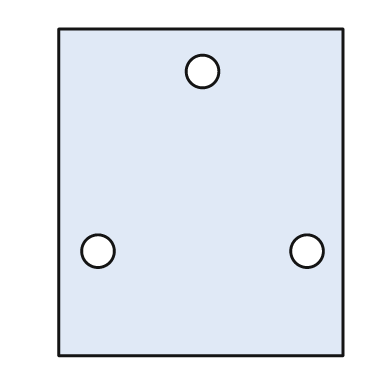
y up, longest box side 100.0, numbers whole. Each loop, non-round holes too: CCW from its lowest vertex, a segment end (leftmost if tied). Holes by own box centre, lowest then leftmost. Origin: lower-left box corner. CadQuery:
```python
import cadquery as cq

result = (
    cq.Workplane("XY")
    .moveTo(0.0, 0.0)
    .lineTo(87.0, 0.0)
    .lineTo(87.0, 100.0)
    .lineTo(0.0, 100.0)
    .close()
    .moveTo(12.0, 32.0)
    .circle(5.0)
    .moveTo(76.0, 32.0)
    .circle(5.0)
    .moveTo(44.0, 87.0)
    .circle(5.0)
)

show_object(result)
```